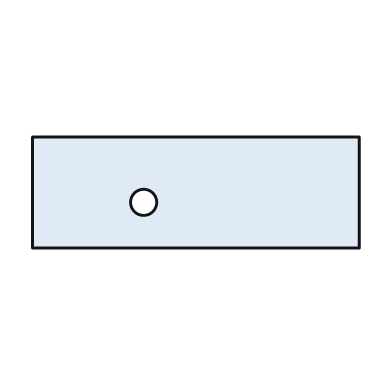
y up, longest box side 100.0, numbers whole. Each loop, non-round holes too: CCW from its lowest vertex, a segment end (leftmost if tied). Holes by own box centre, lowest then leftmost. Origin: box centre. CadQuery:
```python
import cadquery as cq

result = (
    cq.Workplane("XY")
    .moveTo(-50.0, -17.0)
    .lineTo(50.0, -17.0)
    .lineTo(50.0, 17.0)
    .lineTo(-50.0, 17.0)
    .close()
    .moveTo(-16.0, -3.0)
    .circle(4.0)
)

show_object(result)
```